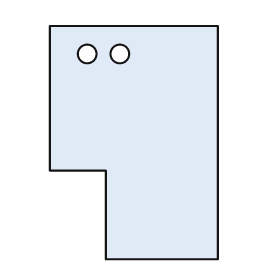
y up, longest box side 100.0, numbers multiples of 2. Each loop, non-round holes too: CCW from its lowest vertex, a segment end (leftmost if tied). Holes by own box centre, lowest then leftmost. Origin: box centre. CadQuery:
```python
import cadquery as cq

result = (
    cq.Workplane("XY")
    .moveTo(-12.0, -50.0)
    .lineTo(36.0, -50.0)
    .lineTo(36.0, 50.0)
    .lineTo(-36.0, 50.0)
    .lineTo(-36.0, -12.0)
    .lineTo(-12.0, -12.0)
    .close()
    .moveTo(-20.0, 38.0)
    .circle(4.0)
    .moveTo(-6.0, 38.0)
    .circle(4.0)
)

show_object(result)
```